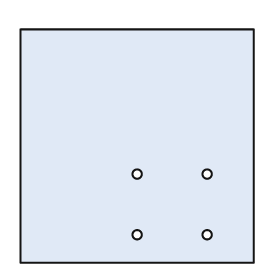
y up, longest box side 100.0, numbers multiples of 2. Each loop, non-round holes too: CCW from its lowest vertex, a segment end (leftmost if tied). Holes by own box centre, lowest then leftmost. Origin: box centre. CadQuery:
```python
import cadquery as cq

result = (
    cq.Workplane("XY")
    .moveTo(-50.0, -50.0)
    .lineTo(50.0, -50.0)
    .lineTo(50.0, 50.0)
    .lineTo(-50.0, 50.0)
    .close()
    .moveTo(0.0, -38.0)
    .circle(2.0)
    .moveTo(30.0, -38.0)
    .circle(2.0)
    .moveTo(0.0, -12.0)
    .circle(2.0)
    .moveTo(30.0, -12.0)
    .circle(2.0)
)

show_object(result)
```